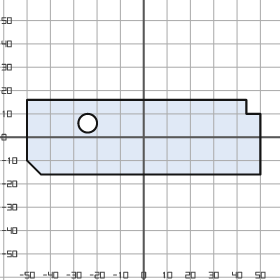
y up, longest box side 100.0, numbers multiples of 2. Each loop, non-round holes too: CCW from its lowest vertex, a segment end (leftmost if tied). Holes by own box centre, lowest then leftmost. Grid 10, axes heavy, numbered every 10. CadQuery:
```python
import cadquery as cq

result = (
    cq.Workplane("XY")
    .moveTo(-44.0, -16.0)
    .lineTo(50.0, -16.0)
    .lineTo(50.0, 10.0)
    .lineTo(44.0, 10.0)
    .lineTo(44.0, 16.0)
    .lineTo(-50.0, 16.0)
    .lineTo(-50.0, -10.0)
    .close()
    .moveTo(-24.0, 6.0)
    .circle(4.0)
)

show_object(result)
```